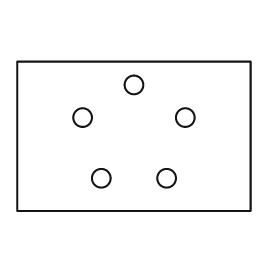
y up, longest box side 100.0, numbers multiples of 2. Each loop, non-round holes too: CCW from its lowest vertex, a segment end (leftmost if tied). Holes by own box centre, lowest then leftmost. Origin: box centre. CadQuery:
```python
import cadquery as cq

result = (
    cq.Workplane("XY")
    .moveTo(-50.0, -32.0)
    .lineTo(50.0, -32.0)
    .lineTo(50.0, 32.0)
    .lineTo(-50.0, 32.0)
    .close()
    .moveTo(-14.0, -18.0)
    .circle(4.0)
    .moveTo(14.0, -18.0)
    .circle(4.0)
    .moveTo(-22.0, 8.0)
    .circle(4.0)
    .moveTo(22.0, 8.0)
    .circle(4.0)
    .moveTo(0.0, 22.0)
    .circle(4.0)
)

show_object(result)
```